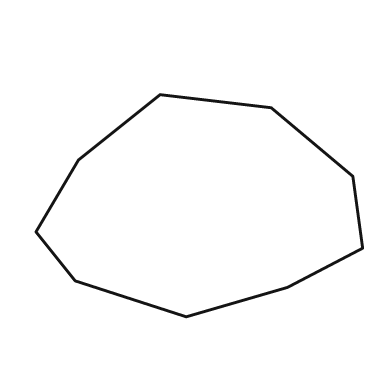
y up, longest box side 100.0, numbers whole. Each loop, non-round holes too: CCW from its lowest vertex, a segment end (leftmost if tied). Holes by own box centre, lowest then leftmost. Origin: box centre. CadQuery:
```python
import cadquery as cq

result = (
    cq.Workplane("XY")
    .moveTo(-4.0, -34.0)
    .lineTo(27.0, -25.0)
    .lineTo(50.0, -13.0)
    .lineTo(47.0, 9.0)
    .lineTo(22.0, 30.0)
    .lineTo(-12.0, 34.0)
    .lineTo(-37.0, 14.0)
    .lineTo(-50.0, -8.0)
    .lineTo(-38.0, -23.0)
    .close()
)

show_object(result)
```